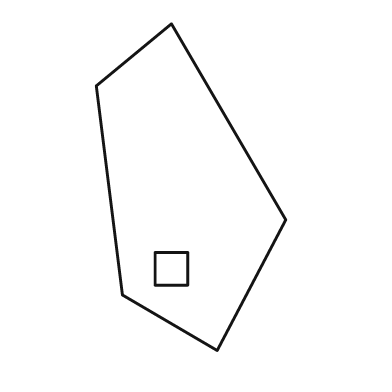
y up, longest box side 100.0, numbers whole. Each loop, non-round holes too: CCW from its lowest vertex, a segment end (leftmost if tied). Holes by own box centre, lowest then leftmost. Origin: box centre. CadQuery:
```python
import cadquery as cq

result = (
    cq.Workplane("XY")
    .moveTo(8.0, -50.0)
    .lineTo(29.0, -10.0)
    .lineTo(-6.0, 50.0)
    .lineTo(-29.0, 31.0)
    .lineTo(-21.0, -33.0)
    .close()
    .moveTo(-11.0, -30.0)
    .lineTo(-1.0, -30.0)
    .lineTo(-1.0, -20.0)
    .lineTo(-11.0, -20.0)
    .close()
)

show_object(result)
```